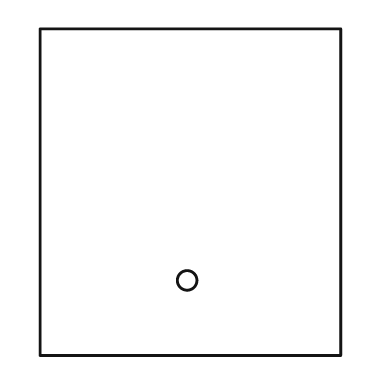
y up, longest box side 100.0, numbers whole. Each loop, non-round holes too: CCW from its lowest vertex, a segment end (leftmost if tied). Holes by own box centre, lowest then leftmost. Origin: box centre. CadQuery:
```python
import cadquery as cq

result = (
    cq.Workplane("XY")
    .moveTo(-46.0, -50.0)
    .lineTo(46.0, -50.0)
    .lineTo(46.0, 50.0)
    .lineTo(-46.0, 50.0)
    .close()
    .moveTo(-1.0, -27.0)
    .circle(3.0)
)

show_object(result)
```